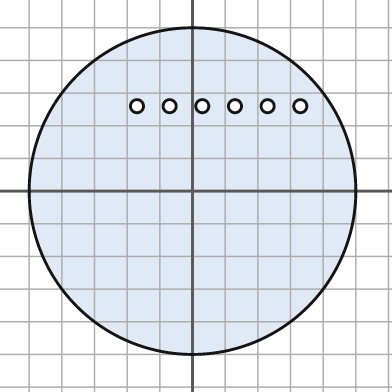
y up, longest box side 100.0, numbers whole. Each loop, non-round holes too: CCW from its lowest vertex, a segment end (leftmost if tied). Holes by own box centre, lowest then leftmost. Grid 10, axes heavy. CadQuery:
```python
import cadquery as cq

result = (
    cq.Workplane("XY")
    .moveTo(0.0, 0.0)
    .circle(50.0)
    .moveTo(-17.0, 26.0)
    .circle(2.0)
    .moveTo(-7.0, 26.0)
    .circle(2.0)
    .moveTo(3.0, 26.0)
    .circle(2.0)
    .moveTo(13.0, 26.0)
    .circle(2.0)
    .moveTo(23.0, 26.0)
    .circle(2.0)
    .moveTo(33.0, 26.0)
    .circle(2.0)
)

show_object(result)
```